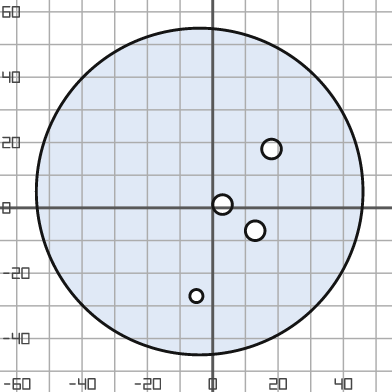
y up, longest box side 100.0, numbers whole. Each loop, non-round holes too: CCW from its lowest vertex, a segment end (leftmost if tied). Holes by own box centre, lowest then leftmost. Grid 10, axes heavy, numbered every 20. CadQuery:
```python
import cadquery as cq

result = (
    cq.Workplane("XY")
    .moveTo(-4.0, 5.0)
    .circle(50.0)
    .moveTo(-5.0, -27.0)
    .circle(2.0)
    .moveTo(13.0, -7.0)
    .circle(3.0)
    .moveTo(3.0, 1.0)
    .circle(3.0)
    .moveTo(18.0, 18.0)
    .circle(3.0)
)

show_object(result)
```